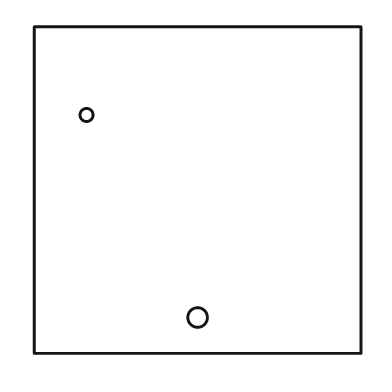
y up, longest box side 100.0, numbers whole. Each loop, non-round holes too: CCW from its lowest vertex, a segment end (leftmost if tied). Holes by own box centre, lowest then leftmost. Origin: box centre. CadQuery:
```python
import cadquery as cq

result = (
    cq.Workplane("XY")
    .moveTo(-50.0, -50.0)
    .lineTo(50.0, -50.0)
    .lineTo(50.0, 50.0)
    .lineTo(-50.0, 50.0)
    .close()
    .moveTo(0.0, -39.0)
    .circle(3.0)
    .moveTo(-34.0, 23.0)
    .circle(2.0)
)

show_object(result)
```